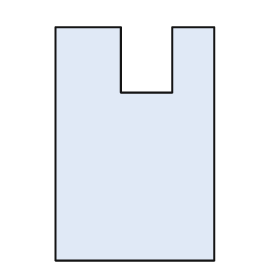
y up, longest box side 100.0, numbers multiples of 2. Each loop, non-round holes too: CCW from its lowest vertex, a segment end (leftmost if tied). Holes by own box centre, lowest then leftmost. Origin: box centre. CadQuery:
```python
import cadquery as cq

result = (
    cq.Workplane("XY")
    .moveTo(-34.0, -50.0)
    .lineTo(34.0, -50.0)
    .lineTo(34.0, 50.0)
    .lineTo(16.0, 50.0)
    .lineTo(16.0, 22.0)
    .lineTo(-6.0, 22.0)
    .lineTo(-6.0, 50.0)
    .lineTo(-34.0, 50.0)
    .close()
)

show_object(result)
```